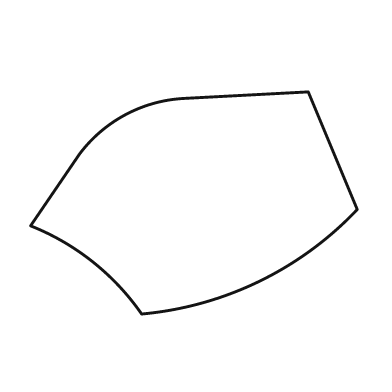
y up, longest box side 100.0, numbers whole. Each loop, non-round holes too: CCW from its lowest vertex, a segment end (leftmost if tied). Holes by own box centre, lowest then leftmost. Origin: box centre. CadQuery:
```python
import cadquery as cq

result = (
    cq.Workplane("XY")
    .moveTo(-16.0, -34.0)
    .threePointArc((20.0, -24.0), (50.0, -2.0))
    .lineTo(35.0, 34.0)
    .lineTo(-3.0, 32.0)
    .threePointArc((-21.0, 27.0), (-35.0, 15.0))
    .lineTo(-50.0, -7.0)
    .threePointArc((-31.0, -18.0), (-16.0, -34.0))
    .close()
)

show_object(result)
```